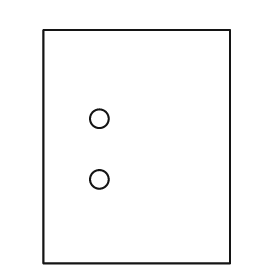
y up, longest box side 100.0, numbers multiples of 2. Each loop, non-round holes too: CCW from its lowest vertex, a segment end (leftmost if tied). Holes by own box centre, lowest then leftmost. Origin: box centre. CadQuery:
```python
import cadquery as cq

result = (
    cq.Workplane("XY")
    .moveTo(-40.0, -50.0)
    .lineTo(40.0, -50.0)
    .lineTo(40.0, 50.0)
    .lineTo(-40.0, 50.0)
    .close()
    .moveTo(-16.0, -14.0)
    .circle(4.0)
    .moveTo(-16.0, 12.0)
    .circle(4.0)
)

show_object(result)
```